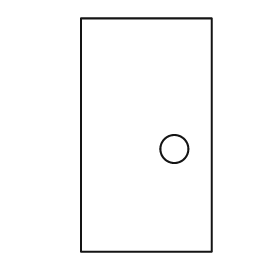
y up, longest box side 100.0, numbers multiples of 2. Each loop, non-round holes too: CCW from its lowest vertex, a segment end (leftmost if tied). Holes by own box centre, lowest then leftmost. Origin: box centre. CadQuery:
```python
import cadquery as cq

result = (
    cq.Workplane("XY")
    .moveTo(-28.0, -50.0)
    .lineTo(28.0, -50.0)
    .lineTo(28.0, 50.0)
    .lineTo(-28.0, 50.0)
    .close()
    .moveTo(12.0, -6.0)
    .circle(6.0)
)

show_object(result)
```